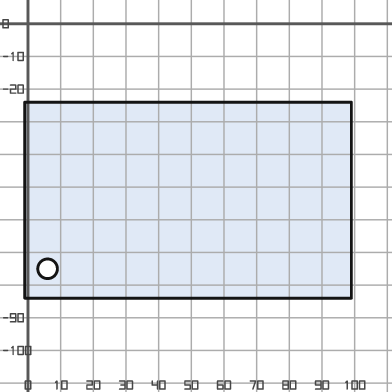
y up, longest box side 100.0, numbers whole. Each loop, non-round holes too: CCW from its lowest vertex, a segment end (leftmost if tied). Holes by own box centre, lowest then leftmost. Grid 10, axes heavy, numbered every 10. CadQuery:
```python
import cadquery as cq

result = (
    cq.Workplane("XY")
    .moveTo(-1.0, -84.0)
    .lineTo(99.0, -84.0)
    .lineTo(99.0, -24.0)
    .lineTo(-1.0, -24.0)
    .close()
    .moveTo(6.0, -75.0)
    .circle(3.0)
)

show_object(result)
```